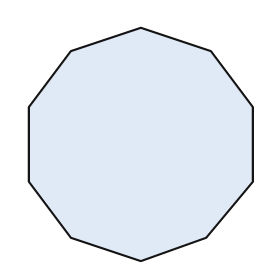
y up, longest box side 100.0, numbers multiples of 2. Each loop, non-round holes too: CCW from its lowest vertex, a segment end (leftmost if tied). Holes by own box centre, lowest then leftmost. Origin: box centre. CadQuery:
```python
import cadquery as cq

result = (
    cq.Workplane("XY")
    .moveTo(0.0, -50.0)
    .lineTo(28.0, -40.0)
    .lineTo(48.0, -16.0)
    .lineTo(48.0, 16.0)
    .lineTo(30.0, 40.0)
    .lineTo(0.0, 50.0)
    .lineTo(-30.0, 40.0)
    .lineTo(-48.0, 16.0)
    .lineTo(-48.0, -16.0)
    .lineTo(-30.0, -40.0)
    .close()
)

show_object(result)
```